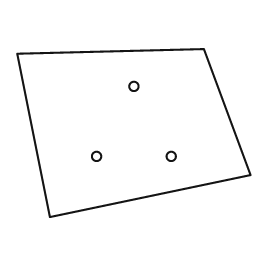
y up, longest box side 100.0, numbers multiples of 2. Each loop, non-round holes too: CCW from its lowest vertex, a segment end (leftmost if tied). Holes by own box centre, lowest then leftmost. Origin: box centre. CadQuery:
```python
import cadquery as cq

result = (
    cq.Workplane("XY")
    .moveTo(-36.0, -36.0)
    .lineTo(50.0, -18.0)
    .lineTo(30.0, 36.0)
    .lineTo(-50.0, 34.0)
    .close()
    .moveTo(-16.0, -10.0)
    .circle(2.0)
    .moveTo(16.0, -10.0)
    .circle(2.0)
    .moveTo(0.0, 20.0)
    .circle(2.0)
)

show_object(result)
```